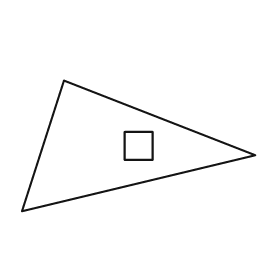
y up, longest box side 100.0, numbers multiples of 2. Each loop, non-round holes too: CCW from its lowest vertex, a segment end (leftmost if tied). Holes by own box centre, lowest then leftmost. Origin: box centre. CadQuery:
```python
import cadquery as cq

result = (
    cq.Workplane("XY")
    .moveTo(-50.0, -28.0)
    .lineTo(50.0, -4.0)
    .lineTo(-32.0, 28.0)
    .close()
    .moveTo(-6.0, -6.0)
    .lineTo(6.0, -6.0)
    .lineTo(6.0, 6.0)
    .lineTo(-6.0, 6.0)
    .close()
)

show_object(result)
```